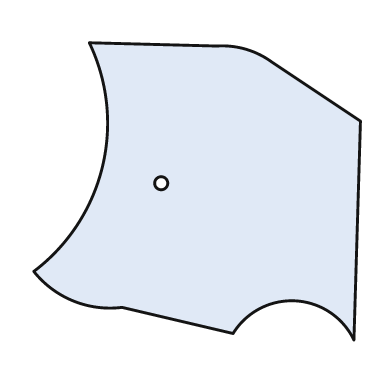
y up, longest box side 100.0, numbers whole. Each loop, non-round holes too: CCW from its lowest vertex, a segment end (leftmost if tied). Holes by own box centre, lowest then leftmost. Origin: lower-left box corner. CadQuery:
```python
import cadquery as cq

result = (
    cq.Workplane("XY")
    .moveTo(98.0, 0.0)
    .lineTo(100.0, 67.0)
    .lineTo(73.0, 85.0)
    .threePointArc((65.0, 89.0), (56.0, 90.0))
    .lineTo(17.0, 91.0)
    .threePointArc((21.0, 53.0), (0.0, 21.0))
    .threePointArc((12.0, 12.0), (27.0, 10.0))
    .lineTo(61.0, 2.0)
    .threePointArc((80.0, 12.0), (98.0, 0.0))
    .close()
    .moveTo(39.0, 48.0)
    .circle(2.0)
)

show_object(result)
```